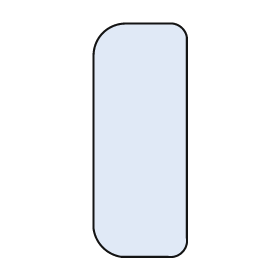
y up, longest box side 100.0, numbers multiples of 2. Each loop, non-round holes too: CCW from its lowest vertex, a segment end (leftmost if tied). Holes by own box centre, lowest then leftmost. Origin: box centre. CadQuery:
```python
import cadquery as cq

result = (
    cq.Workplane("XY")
    .moveTo(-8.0, -50.0)
    .lineTo(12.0, -50.0)
    .threePointArc((18.0, -48.0), (20.0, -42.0))
    .lineTo(20.0, 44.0)
    .threePointArc((18.0, 48.0), (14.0, 50.0))
    .lineTo(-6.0, 50.0)
    .threePointArc((-16.0, 46.0), (-20.0, 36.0))
    .lineTo(-20.0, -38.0)
    .threePointArc((-16.0, -46.0), (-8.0, -50.0))
    .close()
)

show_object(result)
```